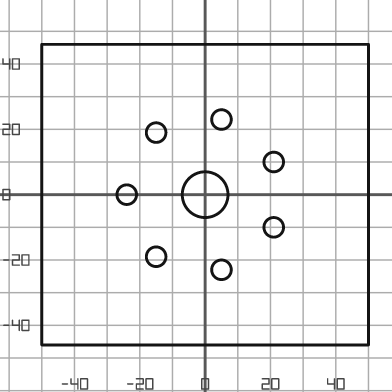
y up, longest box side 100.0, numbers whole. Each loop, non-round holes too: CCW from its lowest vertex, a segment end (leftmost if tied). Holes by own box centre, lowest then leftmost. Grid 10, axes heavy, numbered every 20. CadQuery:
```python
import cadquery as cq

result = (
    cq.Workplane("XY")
    .moveTo(-50.0, -46.0)
    .lineTo(50.0, -46.0)
    .lineTo(50.0, 46.0)
    .lineTo(-50.0, 46.0)
    .close()
    .moveTo(5.0, -23.0)
    .circle(3.0)
    .moveTo(-15.0, -19.0)
    .circle(3.0)
    .moveTo(21.0, -10.0)
    .circle(3.0)
    .moveTo(-24.0, 0.0)
    .circle(3.0)
    .moveTo(0.0, 0.0)
    .circle(7.0)
    .moveTo(21.0, 10.0)
    .circle(3.0)
    .moveTo(-15.0, 19.0)
    .circle(3.0)
    .moveTo(5.0, 23.0)
    .circle(3.0)
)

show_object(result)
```